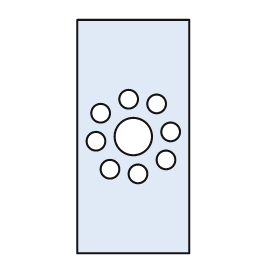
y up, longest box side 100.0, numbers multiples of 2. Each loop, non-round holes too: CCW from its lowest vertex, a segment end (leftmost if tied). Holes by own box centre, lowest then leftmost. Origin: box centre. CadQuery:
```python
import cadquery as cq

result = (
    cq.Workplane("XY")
    .moveTo(-24.0, -50.0)
    .lineTo(24.0, -50.0)
    .lineTo(24.0, 50.0)
    .lineTo(-24.0, 50.0)
    .close()
    .moveTo(2.0, -16.0)
    .circle(4.0)
    .moveTo(-10.0, -14.0)
    .circle(4.0)
    .moveTo(14.0, -10.0)
    .circle(4.0)
    .moveTo(-16.0, -2.0)
    .circle(4.0)
    .moveTo(0.0, 0.0)
    .circle(8.0)
    .moveTo(16.0, 2.0)
    .circle(4.0)
    .moveTo(-14.0, 10.0)
    .circle(4.0)
    .moveTo(10.0, 14.0)
    .circle(4.0)
    .moveTo(-2.0, 16.0)
    .circle(4.0)
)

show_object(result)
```